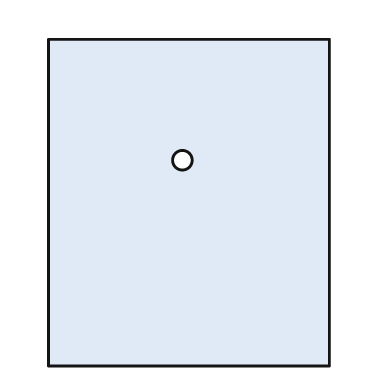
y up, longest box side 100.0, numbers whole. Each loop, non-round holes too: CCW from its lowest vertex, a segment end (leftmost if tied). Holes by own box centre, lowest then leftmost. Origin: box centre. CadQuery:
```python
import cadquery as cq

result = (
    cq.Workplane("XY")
    .moveTo(-43.0, -50.0)
    .lineTo(43.0, -50.0)
    .lineTo(43.0, 50.0)
    .lineTo(-43.0, 50.0)
    .close()
    .moveTo(-2.0, 13.0)
    .circle(3.0)
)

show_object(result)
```